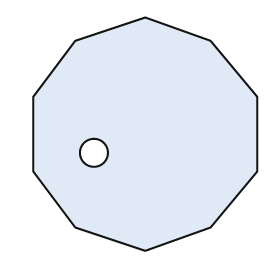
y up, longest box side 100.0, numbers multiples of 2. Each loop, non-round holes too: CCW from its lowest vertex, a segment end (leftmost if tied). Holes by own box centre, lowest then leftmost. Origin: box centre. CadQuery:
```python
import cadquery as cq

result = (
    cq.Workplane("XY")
    .moveTo(0.0, -50.0)
    .lineTo(28.0, -40.0)
    .lineTo(48.0, -16.0)
    .lineTo(48.0, 16.0)
    .lineTo(28.0, 40.0)
    .lineTo(0.0, 50.0)
    .lineTo(-30.0, 40.0)
    .lineTo(-48.0, 16.0)
    .lineTo(-48.0, -16.0)
    .lineTo(-30.0, -40.0)
    .close()
    .moveTo(-22.0, -8.0)
    .circle(6.0)
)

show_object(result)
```